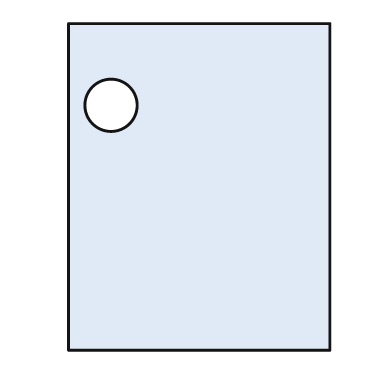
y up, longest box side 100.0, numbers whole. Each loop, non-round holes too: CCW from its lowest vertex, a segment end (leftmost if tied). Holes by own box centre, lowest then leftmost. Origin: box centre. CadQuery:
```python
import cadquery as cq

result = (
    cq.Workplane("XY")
    .moveTo(-40.0, -50.0)
    .lineTo(40.0, -50.0)
    .lineTo(40.0, 50.0)
    .lineTo(-40.0, 50.0)
    .close()
    .moveTo(-27.0, 25.0)
    .circle(8.0)
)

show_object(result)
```